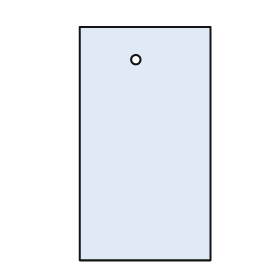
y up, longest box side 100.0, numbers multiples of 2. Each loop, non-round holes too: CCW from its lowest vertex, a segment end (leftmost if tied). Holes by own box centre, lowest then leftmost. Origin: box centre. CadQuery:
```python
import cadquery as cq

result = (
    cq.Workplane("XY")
    .moveTo(-28.0, -50.0)
    .lineTo(28.0, -50.0)
    .lineTo(28.0, 50.0)
    .lineTo(-28.0, 50.0)
    .close()
    .moveTo(-4.0, 36.0)
    .circle(2.0)
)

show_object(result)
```